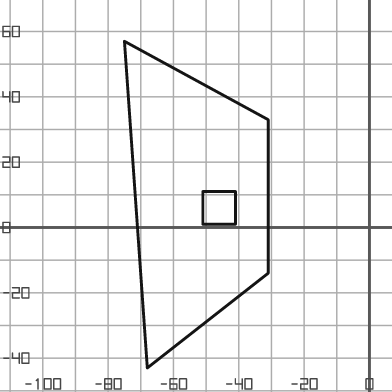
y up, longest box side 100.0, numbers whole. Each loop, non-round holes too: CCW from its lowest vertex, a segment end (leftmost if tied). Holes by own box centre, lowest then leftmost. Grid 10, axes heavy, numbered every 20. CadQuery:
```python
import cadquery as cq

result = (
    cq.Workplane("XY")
    .moveTo(-68.0, -43.0)
    .lineTo(-31.0, -14.0)
    .lineTo(-31.0, 33.0)
    .lineTo(-75.0, 57.0)
    .close()
    .moveTo(-51.0, 1.0)
    .lineTo(-41.0, 1.0)
    .lineTo(-41.0, 11.0)
    .lineTo(-51.0, 11.0)
    .close()
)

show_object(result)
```